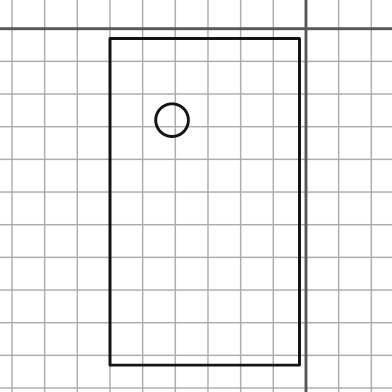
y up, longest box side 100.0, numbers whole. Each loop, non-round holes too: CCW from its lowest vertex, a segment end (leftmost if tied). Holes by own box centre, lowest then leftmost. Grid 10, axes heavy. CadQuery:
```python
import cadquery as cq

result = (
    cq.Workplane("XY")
    .moveTo(-60.0, -103.0)
    .lineTo(-2.0, -103.0)
    .lineTo(-2.0, -3.0)
    .lineTo(-60.0, -3.0)
    .close()
    .moveTo(-41.0, -28.0)
    .circle(5.0)
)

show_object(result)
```